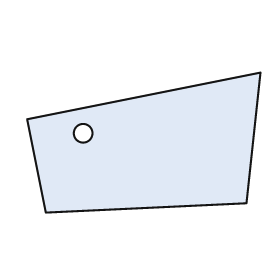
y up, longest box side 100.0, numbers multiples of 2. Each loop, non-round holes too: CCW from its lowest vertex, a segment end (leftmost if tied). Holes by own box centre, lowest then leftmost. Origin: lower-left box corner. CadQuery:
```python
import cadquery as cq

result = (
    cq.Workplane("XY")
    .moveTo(8.0, 0.0)
    .lineTo(94.0, 4.0)
    .lineTo(100.0, 60.0)
    .lineTo(0.0, 40.0)
    .close()
    .moveTo(24.0, 34.0)
    .circle(4.0)
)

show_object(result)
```